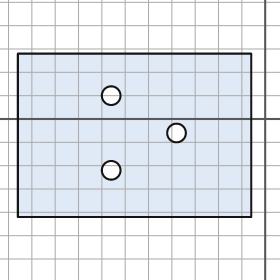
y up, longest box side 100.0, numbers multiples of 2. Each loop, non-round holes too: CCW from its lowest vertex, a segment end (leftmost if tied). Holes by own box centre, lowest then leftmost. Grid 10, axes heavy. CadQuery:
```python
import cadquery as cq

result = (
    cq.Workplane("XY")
    .moveTo(-106.0, -42.0)
    .lineTo(-6.0, -42.0)
    .lineTo(-6.0, 28.0)
    .lineTo(-106.0, 28.0)
    .close()
    .moveTo(-66.0, -22.0)
    .circle(4.0)
    .moveTo(-38.0, -6.0)
    .circle(4.0)
    .moveTo(-66.0, 10.0)
    .circle(4.0)
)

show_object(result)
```